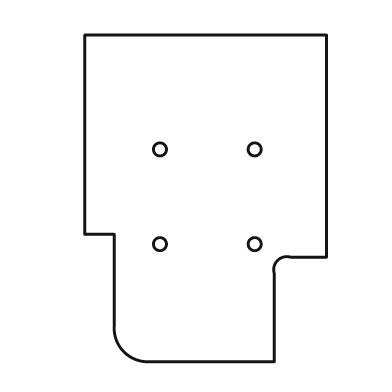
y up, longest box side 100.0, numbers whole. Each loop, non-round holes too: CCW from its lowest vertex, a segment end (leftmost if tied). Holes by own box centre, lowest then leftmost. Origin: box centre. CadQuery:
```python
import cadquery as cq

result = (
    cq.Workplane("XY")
    .moveTo(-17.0, -50.0)
    .lineTo(21.0, -50.0)
    .lineTo(21.0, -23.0)
    .threePointArc((22.0, -19.0), (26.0, -18.0))
    .lineTo(37.0, -18.0)
    .lineTo(37.0, 50.0)
    .lineTo(-37.0, 50.0)
    .lineTo(-37.0, -11.0)
    .lineTo(-28.0, -11.0)
    .lineTo(-28.0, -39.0)
    .threePointArc((-25.0, -47.0), (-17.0, -50.0))
    .close()
    .moveTo(-14.0, -14.0)
    .circle(2.0)
    .moveTo(15.0, -14.0)
    .circle(2.0)
    .moveTo(-14.0, 15.0)
    .circle(2.0)
    .moveTo(15.0, 15.0)
    .circle(2.0)
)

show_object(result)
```